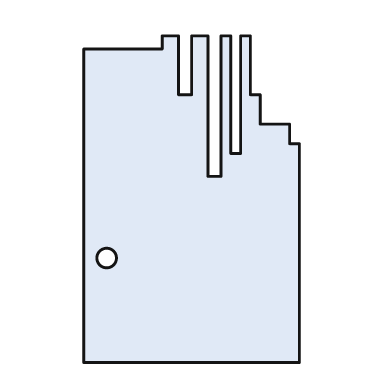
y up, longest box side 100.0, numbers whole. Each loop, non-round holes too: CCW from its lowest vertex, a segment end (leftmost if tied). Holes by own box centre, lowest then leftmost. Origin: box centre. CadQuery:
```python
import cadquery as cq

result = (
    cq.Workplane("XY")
    .moveTo(-33.0, -50.0)
    .lineTo(33.0, -50.0)
    .lineTo(33.0, 17.0)
    .lineTo(30.0, 17.0)
    .lineTo(30.0, 23.0)
    .lineTo(21.0, 23.0)
    .lineTo(21.0, 32.0)
    .lineTo(18.0, 32.0)
    .lineTo(18.0, 50.0)
    .lineTo(15.0, 50.0)
    .lineTo(15.0, 14.0)
    .lineTo(12.0, 14.0)
    .lineTo(12.0, 50.0)
    .lineTo(9.0, 50.0)
    .lineTo(9.0, 7.0)
    .lineTo(5.0, 7.0)
    .lineTo(5.0, 50.0)
    .lineTo(0.0, 50.0)
    .lineTo(0.0, 32.0)
    .lineTo(-4.0, 32.0)
    .lineTo(-4.0, 50.0)
    .lineTo(-9.0, 50.0)
    .lineTo(-9.0, 46.0)
    .lineTo(-33.0, 46.0)
    .close()
    .moveTo(-26.0, -18.0)
    .circle(3.0)
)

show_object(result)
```